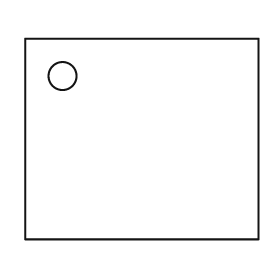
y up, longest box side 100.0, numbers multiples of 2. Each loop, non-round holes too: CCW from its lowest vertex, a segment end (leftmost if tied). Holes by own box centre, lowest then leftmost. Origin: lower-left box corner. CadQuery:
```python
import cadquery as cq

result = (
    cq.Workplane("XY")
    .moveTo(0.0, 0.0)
    .lineTo(100.0, 0.0)
    .lineTo(100.0, 86.0)
    .lineTo(0.0, 86.0)
    .close()
    .moveTo(16.0, 70.0)
    .circle(6.0)
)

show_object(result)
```